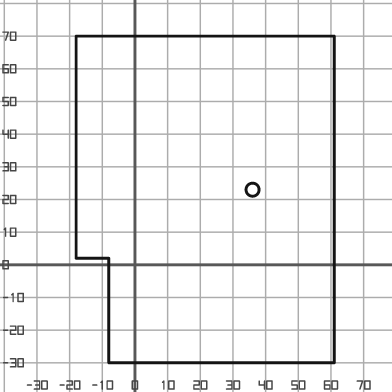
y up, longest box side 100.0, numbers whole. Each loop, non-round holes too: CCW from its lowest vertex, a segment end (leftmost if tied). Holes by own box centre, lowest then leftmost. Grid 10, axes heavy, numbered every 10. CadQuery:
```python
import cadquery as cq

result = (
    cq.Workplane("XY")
    .moveTo(-8.0, -30.0)
    .lineTo(61.0, -30.0)
    .lineTo(61.0, 70.0)
    .lineTo(-18.0, 70.0)
    .lineTo(-18.0, 2.0)
    .lineTo(-8.0, 2.0)
    .close()
    .moveTo(36.0, 23.0)
    .circle(2.0)
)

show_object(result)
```